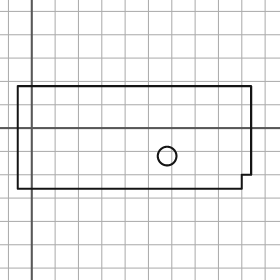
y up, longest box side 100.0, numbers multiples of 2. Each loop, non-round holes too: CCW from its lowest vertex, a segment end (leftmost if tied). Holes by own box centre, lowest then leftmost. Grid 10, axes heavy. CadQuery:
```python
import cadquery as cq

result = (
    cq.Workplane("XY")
    .moveTo(-6.0, -26.0)
    .lineTo(90.0, -26.0)
    .lineTo(90.0, -20.0)
    .lineTo(94.0, -20.0)
    .lineTo(94.0, 18.0)
    .lineTo(-6.0, 18.0)
    .close()
    .moveTo(58.0, -12.0)
    .circle(4.0)
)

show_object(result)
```